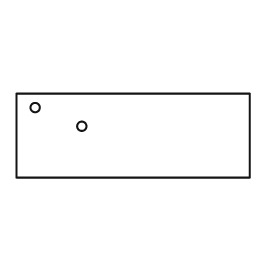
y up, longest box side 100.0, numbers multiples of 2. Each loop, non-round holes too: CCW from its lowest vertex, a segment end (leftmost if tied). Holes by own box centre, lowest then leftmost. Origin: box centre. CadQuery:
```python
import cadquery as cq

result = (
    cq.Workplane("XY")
    .moveTo(-50.0, -18.0)
    .lineTo(50.0, -18.0)
    .lineTo(50.0, 18.0)
    .lineTo(-50.0, 18.0)
    .close()
    .moveTo(-22.0, 4.0)
    .circle(2.0)
    .moveTo(-42.0, 12.0)
    .circle(2.0)
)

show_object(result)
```